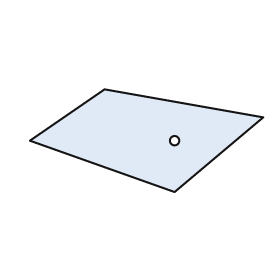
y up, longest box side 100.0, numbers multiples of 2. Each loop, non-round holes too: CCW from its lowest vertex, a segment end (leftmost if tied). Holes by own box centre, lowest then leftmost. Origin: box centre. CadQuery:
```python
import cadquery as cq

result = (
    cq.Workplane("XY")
    .moveTo(12.0, -22.0)
    .lineTo(50.0, 10.0)
    .lineTo(-18.0, 22.0)
    .lineTo(-50.0, 0.0)
    .close()
    .moveTo(12.0, 0.0)
    .circle(2.0)
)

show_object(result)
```